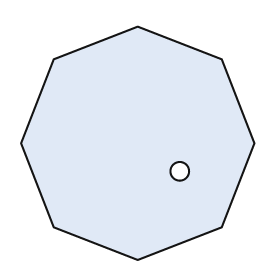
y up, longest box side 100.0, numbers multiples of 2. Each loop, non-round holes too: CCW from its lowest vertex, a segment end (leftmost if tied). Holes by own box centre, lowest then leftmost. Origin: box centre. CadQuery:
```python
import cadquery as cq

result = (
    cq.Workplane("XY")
    .moveTo(0.0, -50.0)
    .lineTo(36.0, -36.0)
    .lineTo(50.0, 0.0)
    .lineTo(36.0, 36.0)
    .lineTo(0.0, 50.0)
    .lineTo(-36.0, 36.0)
    .lineTo(-50.0, 0.0)
    .lineTo(-36.0, -36.0)
    .close()
    .moveTo(18.0, -12.0)
    .circle(4.0)
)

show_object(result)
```